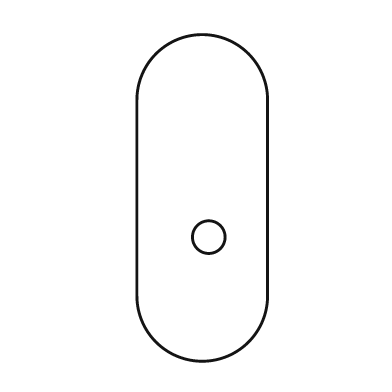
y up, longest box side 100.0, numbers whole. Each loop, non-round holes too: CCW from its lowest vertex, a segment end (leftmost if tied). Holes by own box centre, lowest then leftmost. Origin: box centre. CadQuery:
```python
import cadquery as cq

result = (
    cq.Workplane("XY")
    .moveTo(-20.0, -30.0)
    .threePointArc((0.0, -50.0), (20.0, -30.0))
    .lineTo(20.0, 30.0)
    .threePointArc((0.0, 50.0), (-20.0, 30.0))
    .close()
    .moveTo(2.0, -12.0)
    .circle(5.0)
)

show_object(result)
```